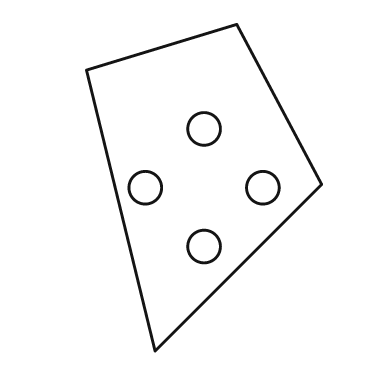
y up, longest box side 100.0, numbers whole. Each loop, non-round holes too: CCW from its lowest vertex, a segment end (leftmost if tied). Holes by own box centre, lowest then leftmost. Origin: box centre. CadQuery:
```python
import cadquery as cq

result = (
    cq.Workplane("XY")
    .moveTo(-15.0, -50.0)
    .lineTo(36.0, 1.0)
    .lineTo(10.0, 50.0)
    .lineTo(-36.0, 36.0)
    .close()
    .moveTo(0.0, -18.0)
    .circle(5.0)
    .moveTo(-18.0, 0.0)
    .circle(5.0)
    .moveTo(18.0, 0.0)
    .circle(5.0)
    .moveTo(0.0, 18.0)
    .circle(5.0)
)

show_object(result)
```